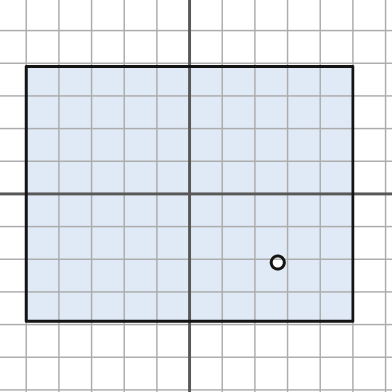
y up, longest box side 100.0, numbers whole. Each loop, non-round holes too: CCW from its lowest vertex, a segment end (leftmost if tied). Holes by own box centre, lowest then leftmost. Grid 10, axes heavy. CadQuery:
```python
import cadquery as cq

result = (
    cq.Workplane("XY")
    .moveTo(-50.0, -39.0)
    .lineTo(50.0, -39.0)
    .lineTo(50.0, 39.0)
    .lineTo(-50.0, 39.0)
    .close()
    .moveTo(27.0, -21.0)
    .circle(2.0)
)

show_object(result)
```